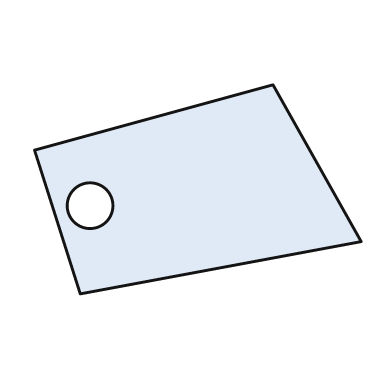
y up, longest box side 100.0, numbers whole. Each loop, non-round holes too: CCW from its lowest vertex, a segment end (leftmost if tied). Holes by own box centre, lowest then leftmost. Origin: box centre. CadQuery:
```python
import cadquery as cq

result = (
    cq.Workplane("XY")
    .moveTo(-36.0, -32.0)
    .lineTo(50.0, -16.0)
    .lineTo(23.0, 32.0)
    .lineTo(-50.0, 12.0)
    .close()
    .moveTo(-33.0, -5.0)
    .circle(7.0)
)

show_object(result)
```